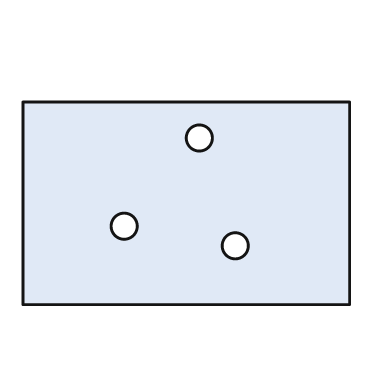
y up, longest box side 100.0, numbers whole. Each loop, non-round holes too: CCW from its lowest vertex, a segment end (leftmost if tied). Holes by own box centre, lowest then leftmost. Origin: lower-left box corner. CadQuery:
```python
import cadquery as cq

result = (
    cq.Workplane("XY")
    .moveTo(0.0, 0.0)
    .lineTo(100.0, 0.0)
    .lineTo(100.0, 62.0)
    .lineTo(0.0, 62.0)
    .close()
    .moveTo(65.0, 18.0)
    .circle(4.0)
    .moveTo(31.0, 24.0)
    .circle(4.0)
    .moveTo(54.0, 51.0)
    .circle(4.0)
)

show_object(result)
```